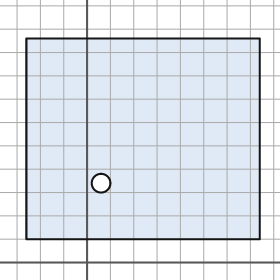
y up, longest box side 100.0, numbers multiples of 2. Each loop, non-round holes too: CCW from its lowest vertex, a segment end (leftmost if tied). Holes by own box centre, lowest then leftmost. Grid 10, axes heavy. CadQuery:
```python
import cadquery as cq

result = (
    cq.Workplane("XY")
    .moveTo(-26.0, 10.0)
    .lineTo(74.0, 10.0)
    .lineTo(74.0, 96.0)
    .lineTo(-26.0, 96.0)
    .close()
    .moveTo(6.0, 34.0)
    .circle(4.0)
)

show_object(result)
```